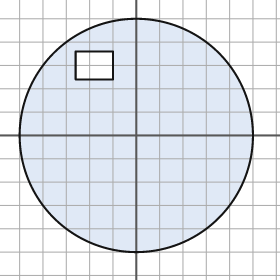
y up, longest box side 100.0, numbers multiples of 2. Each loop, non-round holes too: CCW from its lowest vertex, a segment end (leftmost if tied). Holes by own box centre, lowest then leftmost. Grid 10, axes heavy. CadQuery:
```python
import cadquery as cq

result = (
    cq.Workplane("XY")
    .moveTo(0.0, 0.0)
    .circle(50.0)
    .moveTo(-26.0, 24.0)
    .lineTo(-10.0, 24.0)
    .lineTo(-10.0, 36.0)
    .lineTo(-26.0, 36.0)
    .close()
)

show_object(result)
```